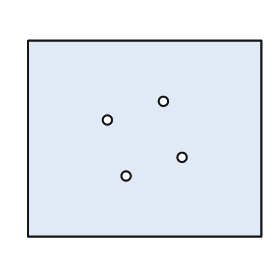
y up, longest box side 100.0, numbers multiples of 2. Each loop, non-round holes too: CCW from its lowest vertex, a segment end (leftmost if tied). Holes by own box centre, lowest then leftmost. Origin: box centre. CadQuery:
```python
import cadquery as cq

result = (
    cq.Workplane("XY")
    .moveTo(-50.0, -42.0)
    .lineTo(50.0, -42.0)
    .lineTo(50.0, 42.0)
    .lineTo(-50.0, 42.0)
    .close()
    .moveTo(-8.0, -16.0)
    .circle(2.0)
    .moveTo(16.0, -8.0)
    .circle(2.0)
    .moveTo(-16.0, 8.0)
    .circle(2.0)
    .moveTo(8.0, 16.0)
    .circle(2.0)
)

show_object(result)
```